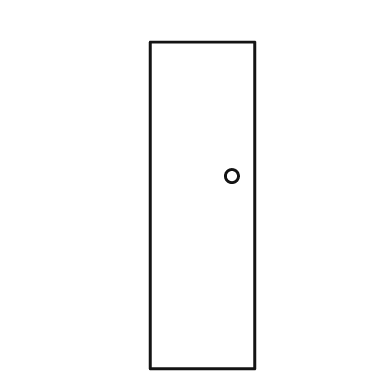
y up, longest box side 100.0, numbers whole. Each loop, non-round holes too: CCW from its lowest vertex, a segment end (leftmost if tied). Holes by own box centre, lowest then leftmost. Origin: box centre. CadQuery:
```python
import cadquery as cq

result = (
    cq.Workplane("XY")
    .moveTo(-16.0, -50.0)
    .lineTo(16.0, -50.0)
    .lineTo(16.0, 50.0)
    .lineTo(-16.0, 50.0)
    .close()
    .moveTo(9.0, 9.0)
    .circle(2.0)
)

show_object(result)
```